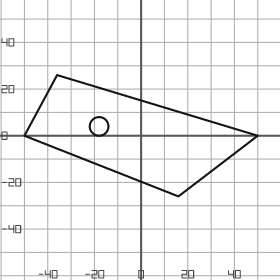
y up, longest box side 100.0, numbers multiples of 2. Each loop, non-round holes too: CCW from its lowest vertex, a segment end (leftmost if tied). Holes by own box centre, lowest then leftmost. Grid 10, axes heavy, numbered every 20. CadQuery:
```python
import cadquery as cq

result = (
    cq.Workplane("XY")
    .moveTo(16.0, -26.0)
    .lineTo(50.0, 0.0)
    .lineTo(-36.0, 26.0)
    .lineTo(-50.0, 0.0)
    .close()
    .moveTo(-18.0, 4.0)
    .circle(4.0)
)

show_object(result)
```